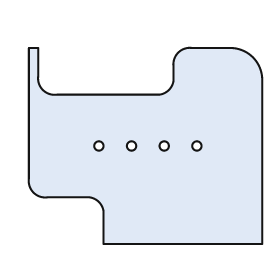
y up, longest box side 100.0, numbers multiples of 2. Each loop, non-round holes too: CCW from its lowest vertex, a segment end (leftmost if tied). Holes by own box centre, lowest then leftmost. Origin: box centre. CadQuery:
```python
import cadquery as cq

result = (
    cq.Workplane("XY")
    .moveTo(-18.0, -42.0)
    .lineTo(50.0, -42.0)
    .lineTo(50.0, 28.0)
    .threePointArc((46.0, 38.0), (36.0, 42.0))
    .lineTo(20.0, 42.0)
    .threePointArc((14.0, 40.0), (12.0, 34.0))
    .lineTo(12.0, 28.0)
    .threePointArc((10.0, 24.0), (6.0, 22.0))
    .lineTo(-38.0, 22.0)
    .threePointArc((-44.0, 24.0), (-46.0, 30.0))
    .lineTo(-46.0, 42.0)
    .lineTo(-50.0, 42.0)
    .lineTo(-50.0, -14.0)
    .threePointArc((-48.0, -20.0), (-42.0, -22.0))
    .lineTo(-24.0, -22.0)
    .threePointArc((-20.0, -24.0), (-18.0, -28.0))
    .close()
    .moveTo(-20.0, 0.0)
    .circle(2.0)
    .moveTo(-6.0, 0.0)
    .circle(2.0)
    .moveTo(8.0, 0.0)
    .circle(2.0)
    .moveTo(22.0, 0.0)
    .circle(2.0)
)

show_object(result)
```